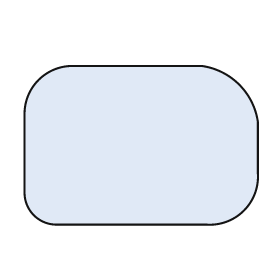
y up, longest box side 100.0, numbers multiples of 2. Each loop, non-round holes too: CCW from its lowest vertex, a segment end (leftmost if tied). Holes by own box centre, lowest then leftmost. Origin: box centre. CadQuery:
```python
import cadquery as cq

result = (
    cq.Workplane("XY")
    .moveTo(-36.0, -34.0)
    .lineTo(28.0, -34.0)
    .threePointArc((44.0, -28.0), (50.0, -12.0))
    .lineTo(50.0, 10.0)
    .threePointArc((42.0, 26.0), (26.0, 34.0))
    .lineTo(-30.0, 34.0)
    .threePointArc((-44.0, 28.0), (-50.0, 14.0))
    .lineTo(-50.0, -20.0)
    .threePointArc((-46.0, -30.0), (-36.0, -34.0))
    .close()
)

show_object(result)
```